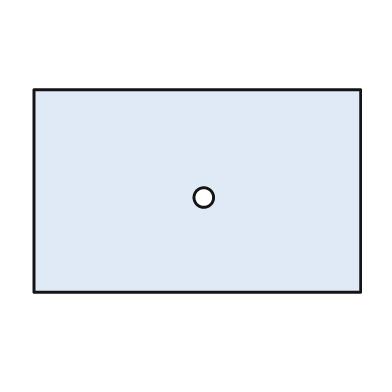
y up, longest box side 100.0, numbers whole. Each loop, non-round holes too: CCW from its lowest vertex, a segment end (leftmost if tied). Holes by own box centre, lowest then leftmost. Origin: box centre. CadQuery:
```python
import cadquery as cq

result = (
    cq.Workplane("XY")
    .moveTo(-50.0, -31.0)
    .lineTo(50.0, -31.0)
    .lineTo(50.0, 31.0)
    .lineTo(-50.0, 31.0)
    .close()
    .moveTo(2.0, -2.0)
    .circle(3.0)
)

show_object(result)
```